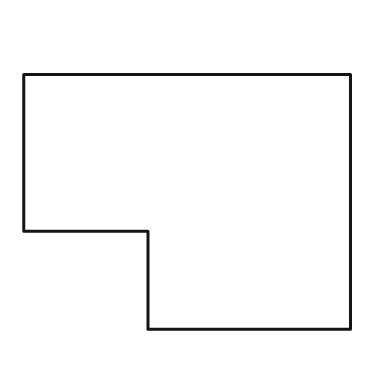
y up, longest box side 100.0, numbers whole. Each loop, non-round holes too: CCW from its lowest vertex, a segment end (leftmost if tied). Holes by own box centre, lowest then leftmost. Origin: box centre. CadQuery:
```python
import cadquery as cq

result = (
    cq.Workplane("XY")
    .moveTo(-12.0, -39.0)
    .lineTo(50.0, -39.0)
    .lineTo(50.0, 39.0)
    .lineTo(-50.0, 39.0)
    .lineTo(-50.0, -9.0)
    .lineTo(-12.0, -9.0)
    .close()
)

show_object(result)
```